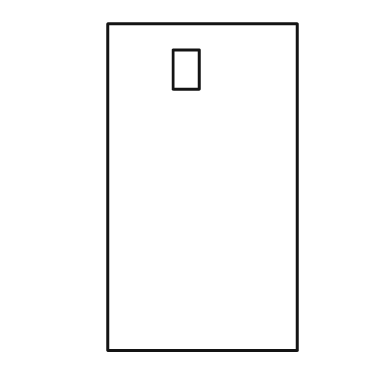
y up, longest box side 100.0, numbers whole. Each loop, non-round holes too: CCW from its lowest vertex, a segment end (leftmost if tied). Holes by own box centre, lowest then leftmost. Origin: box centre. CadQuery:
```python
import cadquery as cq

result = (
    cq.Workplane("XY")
    .moveTo(-29.0, -50.0)
    .lineTo(29.0, -50.0)
    .lineTo(29.0, 50.0)
    .lineTo(-29.0, 50.0)
    .close()
    .moveTo(-9.0, 30.0)
    .lineTo(-1.0, 30.0)
    .lineTo(-1.0, 42.0)
    .lineTo(-9.0, 42.0)
    .close()
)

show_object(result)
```